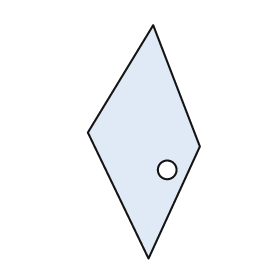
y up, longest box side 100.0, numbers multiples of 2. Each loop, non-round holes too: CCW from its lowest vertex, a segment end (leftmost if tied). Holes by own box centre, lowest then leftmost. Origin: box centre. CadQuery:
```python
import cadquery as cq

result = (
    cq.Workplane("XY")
    .moveTo(2.0, -50.0)
    .lineTo(24.0, -2.0)
    .lineTo(4.0, 50.0)
    .lineTo(-24.0, 4.0)
    .close()
    .moveTo(10.0, -12.0)
    .circle(4.0)
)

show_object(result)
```